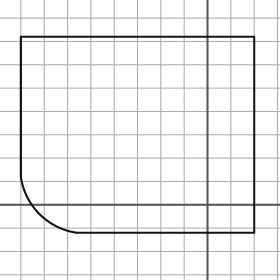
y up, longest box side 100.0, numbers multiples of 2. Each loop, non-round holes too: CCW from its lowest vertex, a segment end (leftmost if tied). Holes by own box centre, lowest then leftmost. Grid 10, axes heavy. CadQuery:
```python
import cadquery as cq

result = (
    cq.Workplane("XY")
    .moveTo(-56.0, -12.0)
    .lineTo(20.0, -12.0)
    .lineTo(20.0, 72.0)
    .lineTo(-80.0, 72.0)
    .lineTo(-80.0, 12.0)
    .threePointArc((-72.0, -4.0), (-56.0, -12.0))
    .close()
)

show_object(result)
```